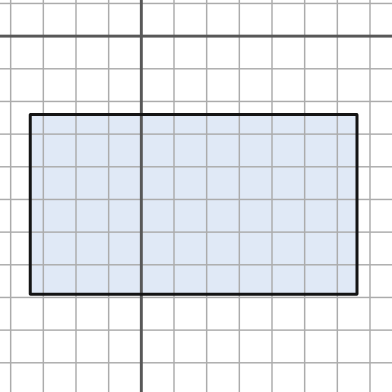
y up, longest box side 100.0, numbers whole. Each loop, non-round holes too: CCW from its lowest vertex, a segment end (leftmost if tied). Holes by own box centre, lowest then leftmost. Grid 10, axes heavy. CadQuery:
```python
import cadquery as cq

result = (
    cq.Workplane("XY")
    .moveTo(-34.0, -79.0)
    .lineTo(66.0, -79.0)
    .lineTo(66.0, -24.0)
    .lineTo(-34.0, -24.0)
    .close()
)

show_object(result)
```